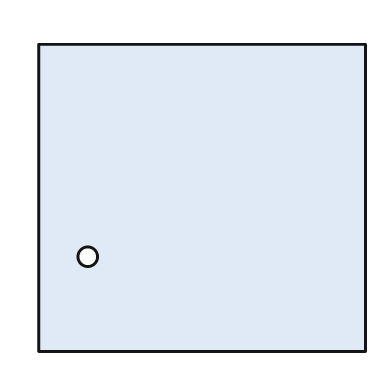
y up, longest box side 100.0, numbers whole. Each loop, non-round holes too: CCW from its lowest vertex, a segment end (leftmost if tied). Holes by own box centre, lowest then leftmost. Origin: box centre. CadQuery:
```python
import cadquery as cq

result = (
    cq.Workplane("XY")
    .moveTo(-50.0, -47.0)
    .lineTo(50.0, -47.0)
    .lineTo(50.0, 47.0)
    .lineTo(-50.0, 47.0)
    .close()
    .moveTo(-35.0, -18.0)
    .circle(3.0)
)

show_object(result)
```